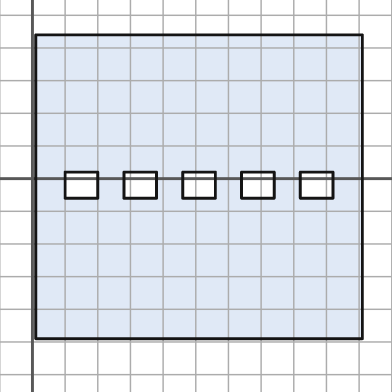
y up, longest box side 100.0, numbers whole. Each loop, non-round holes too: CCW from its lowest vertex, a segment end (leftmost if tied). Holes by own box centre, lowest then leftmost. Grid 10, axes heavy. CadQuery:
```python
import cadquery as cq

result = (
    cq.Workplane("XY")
    .moveTo(1.0, -49.0)
    .lineTo(101.0, -49.0)
    .lineTo(101.0, 44.0)
    .lineTo(1.0, 44.0)
    .close()
    .moveTo(10.0, -6.0)
    .lineTo(20.0, -6.0)
    .lineTo(20.0, 2.0)
    .lineTo(10.0, 2.0)
    .close()
    .moveTo(28.0, -6.0)
    .lineTo(38.0, -6.0)
    .lineTo(38.0, 2.0)
    .lineTo(28.0, 2.0)
    .close()
    .moveTo(46.0, -6.0)
    .lineTo(56.0, -6.0)
    .lineTo(56.0, 2.0)
    .lineTo(46.0, 2.0)
    .close()
    .moveTo(64.0, -6.0)
    .lineTo(74.0, -6.0)
    .lineTo(74.0, 2.0)
    .lineTo(64.0, 2.0)
    .close()
    .moveTo(82.0, -6.0)
    .lineTo(92.0, -6.0)
    .lineTo(92.0, 2.0)
    .lineTo(82.0, 2.0)
    .close()
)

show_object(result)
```